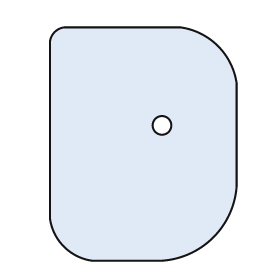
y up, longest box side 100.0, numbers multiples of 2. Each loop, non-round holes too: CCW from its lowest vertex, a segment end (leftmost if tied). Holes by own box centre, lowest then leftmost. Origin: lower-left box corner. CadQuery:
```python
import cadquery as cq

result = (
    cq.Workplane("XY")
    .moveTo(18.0, 0.0)
    .lineTo(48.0, 0.0)
    .threePointArc((70.0, 10.0), (80.0, 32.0))
    .lineTo(80.0, 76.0)
    .threePointArc((72.0, 92.0), (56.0, 100.0))
    .lineTo(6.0, 100.0)
    .threePointArc((2.0, 98.0), (0.0, 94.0))
    .lineTo(0.0, 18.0)
    .threePointArc((6.0, 6.0), (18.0, 0.0))
    .close()
    .moveTo(48.0, 58.0)
    .circle(4.0)
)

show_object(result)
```